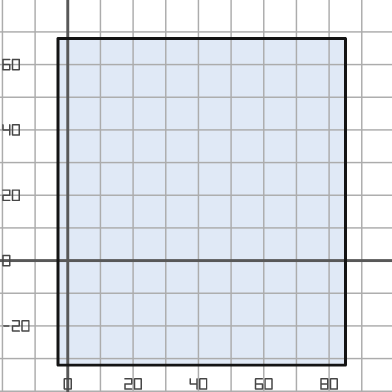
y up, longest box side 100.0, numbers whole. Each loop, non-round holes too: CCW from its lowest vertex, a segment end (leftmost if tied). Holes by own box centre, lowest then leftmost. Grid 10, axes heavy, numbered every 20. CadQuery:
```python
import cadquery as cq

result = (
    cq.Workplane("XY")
    .moveTo(-3.0, -32.0)
    .lineTo(85.0, -32.0)
    .lineTo(85.0, 68.0)
    .lineTo(-3.0, 68.0)
    .close()
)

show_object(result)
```